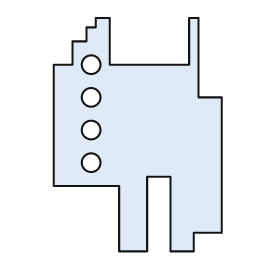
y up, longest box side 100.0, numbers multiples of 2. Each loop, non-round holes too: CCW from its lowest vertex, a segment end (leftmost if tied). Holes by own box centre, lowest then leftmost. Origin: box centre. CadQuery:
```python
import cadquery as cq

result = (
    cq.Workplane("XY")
    .moveTo(-8.0, -50.0)
    .lineTo(4.0, -50.0)
    .lineTo(4.0, -18.0)
    .lineTo(14.0, -18.0)
    .lineTo(14.0, -50.0)
    .lineTo(24.0, -50.0)
    .lineTo(24.0, -42.0)
    .lineTo(36.0, -42.0)
    .lineTo(36.0, 16.0)
    .lineTo(26.0, 16.0)
    .lineTo(26.0, 50.0)
    .lineTo(22.0, 50.0)
    .lineTo(22.0, 30.0)
    .lineTo(-12.0, 30.0)
    .lineTo(-12.0, 50.0)
    .lineTo(-18.0, 50.0)
    .lineTo(-18.0, 46.0)
    .lineTo(-22.0, 46.0)
    .lineTo(-22.0, 40.0)
    .lineTo(-28.0, 40.0)
    .lineTo(-28.0, 30.0)
    .lineTo(-36.0, 30.0)
    .lineTo(-36.0, -22.0)
    .lineTo(-8.0, -22.0)
    .close()
    .moveTo(-20.0, -12.0)
    .circle(4.0)
    .moveTo(-20.0, 2.0)
    .circle(4.0)
    .moveTo(-20.0, 16.0)
    .circle(4.0)
    .moveTo(-20.0, 30.0)
    .circle(4.0)
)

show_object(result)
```